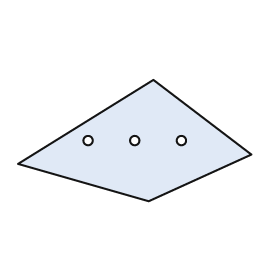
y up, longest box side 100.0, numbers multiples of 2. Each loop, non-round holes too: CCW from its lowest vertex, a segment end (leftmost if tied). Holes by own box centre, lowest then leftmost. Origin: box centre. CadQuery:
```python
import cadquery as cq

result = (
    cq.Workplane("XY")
    .moveTo(6.0, -26.0)
    .lineTo(50.0, -6.0)
    .lineTo(8.0, 26.0)
    .lineTo(-50.0, -10.0)
    .close()
    .moveTo(-20.0, 0.0)
    .circle(2.0)
    .moveTo(0.0, 0.0)
    .circle(2.0)
    .moveTo(20.0, 0.0)
    .circle(2.0)
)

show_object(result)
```